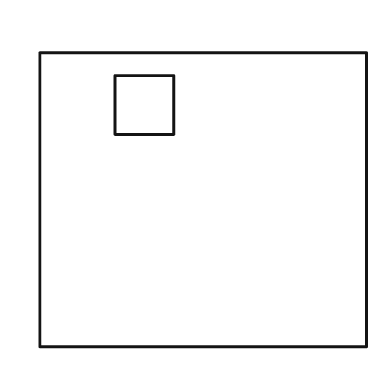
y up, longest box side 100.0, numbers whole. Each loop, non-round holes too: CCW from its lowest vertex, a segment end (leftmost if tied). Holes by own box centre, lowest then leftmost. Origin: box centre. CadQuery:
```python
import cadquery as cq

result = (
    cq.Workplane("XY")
    .moveTo(-50.0, -45.0)
    .lineTo(50.0, -45.0)
    .lineTo(50.0, 45.0)
    .lineTo(-50.0, 45.0)
    .close()
    .moveTo(-27.0, 20.0)
    .lineTo(-9.0, 20.0)
    .lineTo(-9.0, 38.0)
    .lineTo(-27.0, 38.0)
    .close()
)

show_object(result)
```